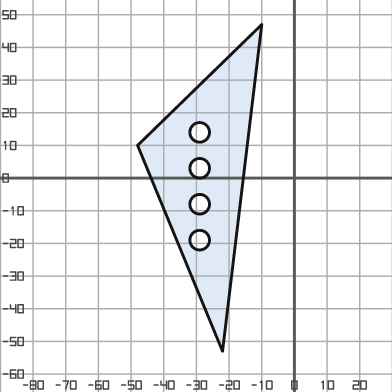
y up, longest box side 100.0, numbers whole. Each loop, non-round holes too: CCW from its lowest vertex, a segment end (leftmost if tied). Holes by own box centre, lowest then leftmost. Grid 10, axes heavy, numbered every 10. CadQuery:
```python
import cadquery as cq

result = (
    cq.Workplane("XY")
    .moveTo(-22.0, -53.0)
    .lineTo(-10.0, 47.0)
    .lineTo(-48.0, 10.0)
    .close()
    .moveTo(-29.0, -19.0)
    .circle(3.0)
    .moveTo(-29.0, -8.0)
    .circle(3.0)
    .moveTo(-29.0, 3.0)
    .circle(3.0)
    .moveTo(-29.0, 14.0)
    .circle(3.0)
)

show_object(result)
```